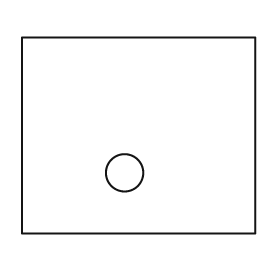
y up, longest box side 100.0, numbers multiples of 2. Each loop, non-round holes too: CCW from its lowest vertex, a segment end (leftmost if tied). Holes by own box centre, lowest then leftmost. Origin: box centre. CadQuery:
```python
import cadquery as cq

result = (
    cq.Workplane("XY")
    .moveTo(-50.0, -42.0)
    .lineTo(50.0, -42.0)
    .lineTo(50.0, 42.0)
    .lineTo(-50.0, 42.0)
    .close()
    .moveTo(-6.0, -16.0)
    .circle(8.0)
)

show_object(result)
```